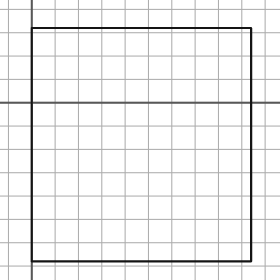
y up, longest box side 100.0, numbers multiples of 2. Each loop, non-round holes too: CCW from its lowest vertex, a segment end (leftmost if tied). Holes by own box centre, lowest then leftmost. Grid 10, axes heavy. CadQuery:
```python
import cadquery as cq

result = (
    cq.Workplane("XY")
    .moveTo(0.0, -68.0)
    .lineTo(94.0, -68.0)
    .lineTo(94.0, 32.0)
    .lineTo(0.0, 32.0)
    .close()
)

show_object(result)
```